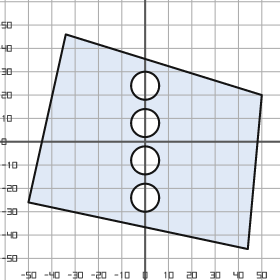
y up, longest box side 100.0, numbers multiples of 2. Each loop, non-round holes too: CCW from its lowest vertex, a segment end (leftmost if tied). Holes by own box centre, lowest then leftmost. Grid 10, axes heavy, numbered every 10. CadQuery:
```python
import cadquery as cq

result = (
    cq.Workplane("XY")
    .moveTo(44.0, -46.0)
    .lineTo(50.0, 20.0)
    .lineTo(-34.0, 46.0)
    .lineTo(-50.0, -26.0)
    .close()
    .moveTo(0.0, -24.0)
    .circle(6.0)
    .moveTo(0.0, -8.0)
    .circle(6.0)
    .moveTo(0.0, 8.0)
    .circle(6.0)
    .moveTo(0.0, 24.0)
    .circle(6.0)
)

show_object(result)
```